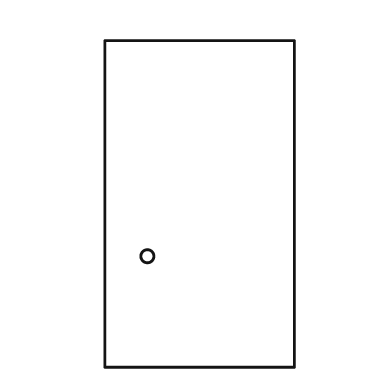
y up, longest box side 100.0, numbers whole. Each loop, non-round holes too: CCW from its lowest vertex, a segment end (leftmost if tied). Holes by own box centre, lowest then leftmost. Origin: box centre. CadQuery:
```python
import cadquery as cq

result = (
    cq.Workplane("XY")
    .moveTo(-29.0, -50.0)
    .lineTo(29.0, -50.0)
    .lineTo(29.0, 50.0)
    .lineTo(-29.0, 50.0)
    .close()
    .moveTo(-16.0, -16.0)
    .circle(2.0)
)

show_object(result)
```